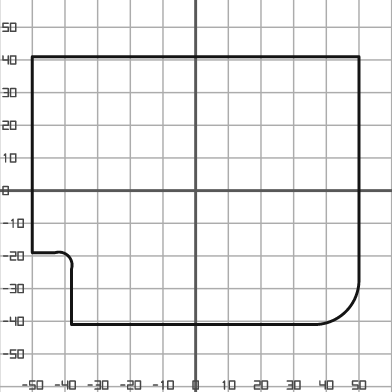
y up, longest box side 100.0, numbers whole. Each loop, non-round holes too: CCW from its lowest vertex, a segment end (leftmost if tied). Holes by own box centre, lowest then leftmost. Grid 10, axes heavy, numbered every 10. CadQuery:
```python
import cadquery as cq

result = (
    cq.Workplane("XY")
    .moveTo(-38.0, -41.0)
    .lineTo(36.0, -41.0)
    .threePointArc((46.0, -37.0), (50.0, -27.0))
    .lineTo(50.0, 41.0)
    .lineTo(-50.0, 41.0)
    .lineTo(-50.0, -19.0)
    .lineTo(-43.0, -19.0)
    .threePointArc((-39.0, -20.0), (-38.0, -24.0))
    .close()
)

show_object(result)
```